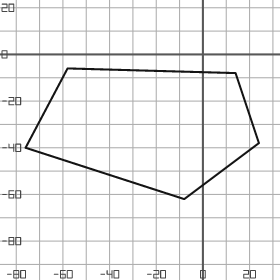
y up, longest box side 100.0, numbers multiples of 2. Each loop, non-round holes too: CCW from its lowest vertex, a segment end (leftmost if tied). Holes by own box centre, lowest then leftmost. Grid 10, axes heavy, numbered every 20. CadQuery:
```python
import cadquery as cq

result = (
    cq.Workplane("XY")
    .moveTo(-8.0, -62.0)
    .lineTo(24.0, -38.0)
    .lineTo(14.0, -8.0)
    .lineTo(-58.0, -6.0)
    .lineTo(-76.0, -40.0)
    .close()
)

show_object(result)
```